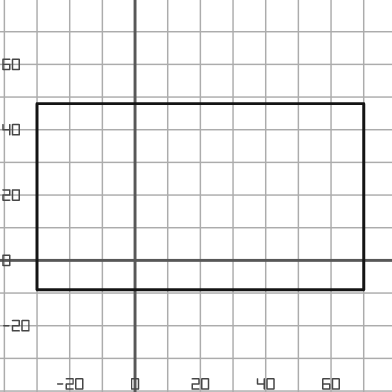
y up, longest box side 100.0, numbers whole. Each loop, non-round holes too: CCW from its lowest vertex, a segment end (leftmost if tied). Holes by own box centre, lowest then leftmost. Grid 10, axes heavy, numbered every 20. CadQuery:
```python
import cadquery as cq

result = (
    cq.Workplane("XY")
    .moveTo(-30.0, -9.0)
    .lineTo(70.0, -9.0)
    .lineTo(70.0, 48.0)
    .lineTo(-30.0, 48.0)
    .close()
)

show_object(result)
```